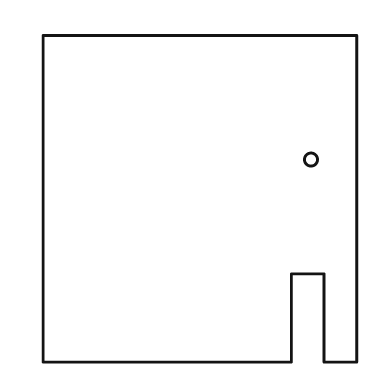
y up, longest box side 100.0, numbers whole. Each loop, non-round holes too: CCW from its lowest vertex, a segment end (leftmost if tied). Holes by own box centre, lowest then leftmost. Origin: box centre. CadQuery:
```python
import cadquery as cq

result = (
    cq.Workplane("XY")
    .moveTo(-48.0, -50.0)
    .lineTo(28.0, -50.0)
    .lineTo(28.0, -23.0)
    .lineTo(38.0, -23.0)
    .lineTo(38.0, -50.0)
    .lineTo(48.0, -50.0)
    .lineTo(48.0, 50.0)
    .lineTo(-48.0, 50.0)
    .close()
    .moveTo(34.0, 12.0)
    .circle(2.0)
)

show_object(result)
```